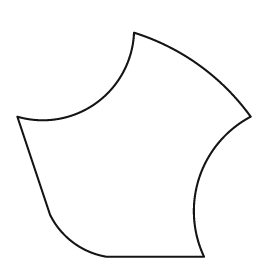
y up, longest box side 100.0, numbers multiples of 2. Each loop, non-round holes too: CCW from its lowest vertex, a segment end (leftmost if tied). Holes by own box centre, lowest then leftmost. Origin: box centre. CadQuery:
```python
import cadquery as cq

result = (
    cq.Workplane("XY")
    .moveTo(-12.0, -48.0)
    .lineTo(30.0, -48.0)
    .threePointArc((28.0, -14.0), (50.0, 12.0))
    .threePointArc((28.0, 34.0), (0.0, 48.0))
    .threePointArc((-16.0, 18.0), (-50.0, 12.0))
    .lineTo(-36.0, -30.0)
    .threePointArc((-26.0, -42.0), (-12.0, -48.0))
    .close()
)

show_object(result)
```